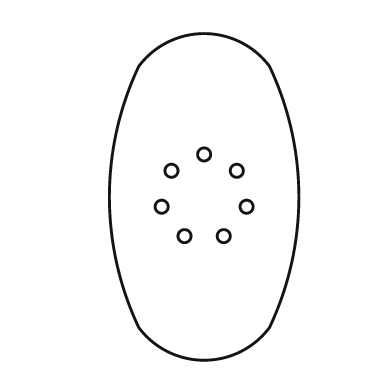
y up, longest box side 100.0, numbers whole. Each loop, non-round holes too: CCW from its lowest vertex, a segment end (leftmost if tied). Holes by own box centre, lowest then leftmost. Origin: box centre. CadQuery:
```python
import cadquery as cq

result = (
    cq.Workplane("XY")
    .moveTo(-20.0, -40.0)
    .threePointArc((0.0, -50.0), (20.0, -40.0))
    .threePointArc((29.0, 0.0), (20.0, 40.0))
    .threePointArc((0.0, 50.0), (-20.0, 40.0))
    .threePointArc((-29.0, 0.0), (-20.0, -40.0))
    .close()
    .moveTo(-6.0, -12.0)
    .circle(2.0)
    .moveTo(6.0, -12.0)
    .circle(2.0)
    .moveTo(-13.0, -3.0)
    .circle(2.0)
    .moveTo(13.0, -3.0)
    .circle(2.0)
    .moveTo(-10.0, 8.0)
    .circle(2.0)
    .moveTo(10.0, 8.0)
    .circle(2.0)
    .moveTo(0.0, 13.0)
    .circle(2.0)
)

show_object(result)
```